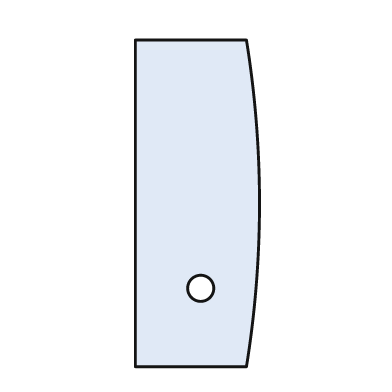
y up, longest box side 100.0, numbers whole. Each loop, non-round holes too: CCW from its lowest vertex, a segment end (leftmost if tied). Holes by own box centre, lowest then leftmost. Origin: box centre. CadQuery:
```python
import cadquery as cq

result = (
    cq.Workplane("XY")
    .moveTo(-19.0, -50.0)
    .lineTo(15.0, -50.0)
    .threePointArc((19.0, 0.0), (15.0, 50.0))
    .lineTo(-19.0, 50.0)
    .close()
    .moveTo(1.0, -26.0)
    .circle(4.0)
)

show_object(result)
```